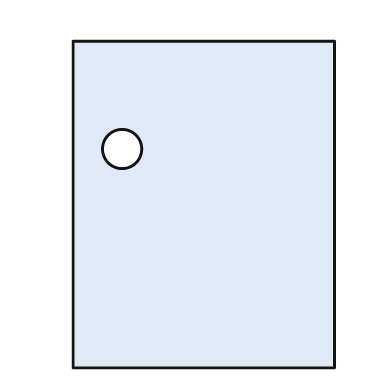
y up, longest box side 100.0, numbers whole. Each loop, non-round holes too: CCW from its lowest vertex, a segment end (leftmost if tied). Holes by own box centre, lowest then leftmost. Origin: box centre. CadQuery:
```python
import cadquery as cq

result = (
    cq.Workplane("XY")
    .moveTo(-40.0, -50.0)
    .lineTo(40.0, -50.0)
    .lineTo(40.0, 50.0)
    .lineTo(-40.0, 50.0)
    .close()
    .moveTo(-25.0, 17.0)
    .circle(6.0)
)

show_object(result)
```